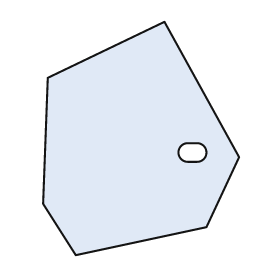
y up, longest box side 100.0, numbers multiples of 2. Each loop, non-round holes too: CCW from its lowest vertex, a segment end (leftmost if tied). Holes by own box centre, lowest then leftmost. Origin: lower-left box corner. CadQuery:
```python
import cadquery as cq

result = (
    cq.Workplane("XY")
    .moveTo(14.0, 0.0)
    .lineTo(70.0, 12.0)
    .lineTo(84.0, 42.0)
    .lineTo(52.0, 100.0)
    .lineTo(2.0, 76.0)
    .lineTo(0.0, 22.0)
    .close()
    .moveTo(62.0, 40.0)
    .lineTo(66.0, 40.0)
    .threePointArc((70.0, 44.0), (66.0, 48.0))
    .lineTo(62.0, 48.0)
    .threePointArc((58.0, 44.0), (62.0, 40.0))
    .close()
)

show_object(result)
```